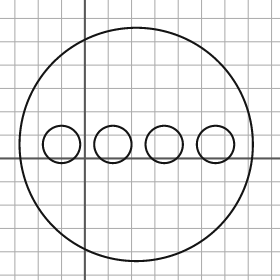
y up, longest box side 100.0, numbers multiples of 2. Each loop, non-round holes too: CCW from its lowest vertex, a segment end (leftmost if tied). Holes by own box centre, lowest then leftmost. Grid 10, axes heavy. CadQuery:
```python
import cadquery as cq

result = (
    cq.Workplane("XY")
    .moveTo(22.0, 6.0)
    .circle(50.0)
    .moveTo(-10.0, 6.0)
    .circle(8.0)
    .moveTo(12.0, 6.0)
    .circle(8.0)
    .moveTo(34.0, 6.0)
    .circle(8.0)
    .moveTo(56.0, 6.0)
    .circle(8.0)
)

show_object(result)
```